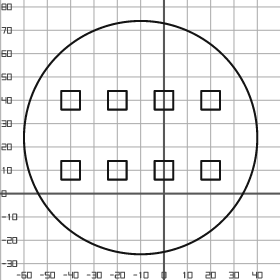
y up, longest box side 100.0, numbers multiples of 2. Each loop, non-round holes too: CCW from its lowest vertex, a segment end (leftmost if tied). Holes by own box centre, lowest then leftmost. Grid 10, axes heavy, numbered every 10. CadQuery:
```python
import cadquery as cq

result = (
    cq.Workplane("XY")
    .moveTo(-10.0, 24.0)
    .circle(50.0)
    .moveTo(-44.0, 6.0)
    .lineTo(-36.0, 6.0)
    .lineTo(-36.0, 14.0)
    .lineTo(-44.0, 14.0)
    .close()
    .moveTo(-24.0, 6.0)
    .lineTo(-16.0, 6.0)
    .lineTo(-16.0, 14.0)
    .lineTo(-24.0, 14.0)
    .close()
    .moveTo(-4.0, 6.0)
    .lineTo(4.0, 6.0)
    .lineTo(4.0, 14.0)
    .lineTo(-4.0, 14.0)
    .close()
    .moveTo(16.0, 6.0)
    .lineTo(24.0, 6.0)
    .lineTo(24.0, 14.0)
    .lineTo(16.0, 14.0)
    .close()
    .moveTo(-44.0, 36.0)
    .lineTo(-36.0, 36.0)
    .lineTo(-36.0, 44.0)
    .lineTo(-44.0, 44.0)
    .close()
    .moveTo(-24.0, 36.0)
    .lineTo(-16.0, 36.0)
    .lineTo(-16.0, 44.0)
    .lineTo(-24.0, 44.0)
    .close()
    .moveTo(-4.0, 36.0)
    .lineTo(4.0, 36.0)
    .lineTo(4.0, 44.0)
    .lineTo(-4.0, 44.0)
    .close()
    .moveTo(16.0, 36.0)
    .lineTo(24.0, 36.0)
    .lineTo(24.0, 44.0)
    .lineTo(16.0, 44.0)
    .close()
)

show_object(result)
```